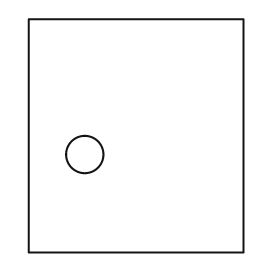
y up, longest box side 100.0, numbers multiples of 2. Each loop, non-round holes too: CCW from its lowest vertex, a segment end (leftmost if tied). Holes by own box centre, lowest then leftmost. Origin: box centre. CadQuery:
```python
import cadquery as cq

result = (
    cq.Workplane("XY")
    .moveTo(-46.0, -50.0)
    .lineTo(46.0, -50.0)
    .lineTo(46.0, 50.0)
    .lineTo(-46.0, 50.0)
    .close()
    .moveTo(-22.0, -8.0)
    .circle(8.0)
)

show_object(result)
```